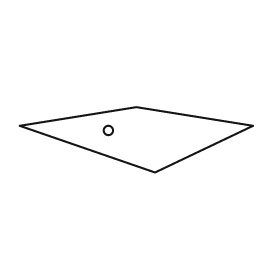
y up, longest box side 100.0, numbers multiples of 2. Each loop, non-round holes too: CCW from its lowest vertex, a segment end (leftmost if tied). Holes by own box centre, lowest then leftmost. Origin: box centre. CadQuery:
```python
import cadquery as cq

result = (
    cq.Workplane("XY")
    .moveTo(8.0, -14.0)
    .lineTo(50.0, 6.0)
    .lineTo(0.0, 14.0)
    .lineTo(-50.0, 6.0)
    .close()
    .moveTo(-12.0, 4.0)
    .circle(2.0)
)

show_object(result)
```